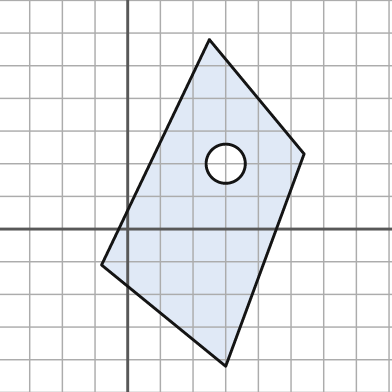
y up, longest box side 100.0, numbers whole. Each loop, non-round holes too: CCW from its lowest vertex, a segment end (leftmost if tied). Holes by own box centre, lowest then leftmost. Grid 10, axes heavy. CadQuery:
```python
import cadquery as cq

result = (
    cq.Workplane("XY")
    .moveTo(30.0, -42.0)
    .lineTo(54.0, 23.0)
    .lineTo(25.0, 58.0)
    .lineTo(-8.0, -11.0)
    .close()
    .moveTo(30.0, 20.0)
    .circle(6.0)
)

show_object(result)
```